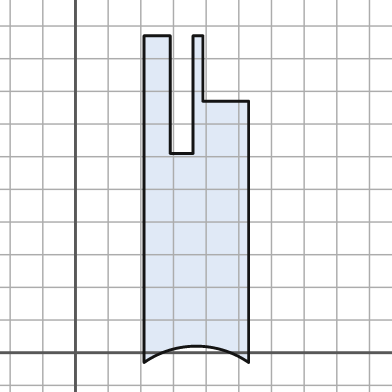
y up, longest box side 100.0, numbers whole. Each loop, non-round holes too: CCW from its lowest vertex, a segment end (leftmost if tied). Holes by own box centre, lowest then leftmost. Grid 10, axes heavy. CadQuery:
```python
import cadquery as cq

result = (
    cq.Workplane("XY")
    .moveTo(21.0, -3.0)
    .threePointArc((37.0, 2.0), (53.0, -3.0))
    .lineTo(53.0, 77.0)
    .lineTo(39.0, 77.0)
    .lineTo(39.0, 97.0)
    .lineTo(36.0, 97.0)
    .lineTo(36.0, 61.0)
    .lineTo(29.0, 61.0)
    .lineTo(29.0, 97.0)
    .lineTo(21.0, 97.0)
    .close()
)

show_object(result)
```